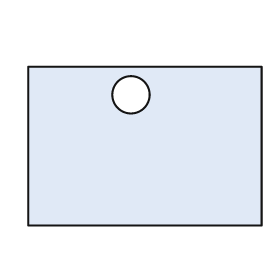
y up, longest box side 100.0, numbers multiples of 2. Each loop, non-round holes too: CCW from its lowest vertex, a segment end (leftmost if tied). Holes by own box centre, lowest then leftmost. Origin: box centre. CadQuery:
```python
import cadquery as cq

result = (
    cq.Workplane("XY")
    .moveTo(-50.0, -34.0)
    .lineTo(50.0, -34.0)
    .lineTo(50.0, 34.0)
    .lineTo(-50.0, 34.0)
    .close()
    .moveTo(-6.0, 22.0)
    .circle(8.0)
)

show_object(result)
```